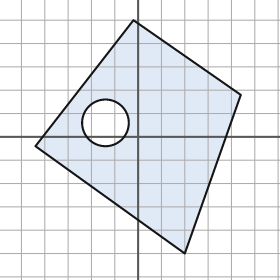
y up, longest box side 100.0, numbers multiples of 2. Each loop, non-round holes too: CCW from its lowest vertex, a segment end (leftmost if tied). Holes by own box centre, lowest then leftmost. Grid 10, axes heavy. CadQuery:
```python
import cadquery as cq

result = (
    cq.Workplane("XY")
    .moveTo(20.0, -50.0)
    .lineTo(44.0, 18.0)
    .lineTo(-2.0, 50.0)
    .lineTo(-44.0, -4.0)
    .close()
    .moveTo(-14.0, 6.0)
    .circle(10.0)
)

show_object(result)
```